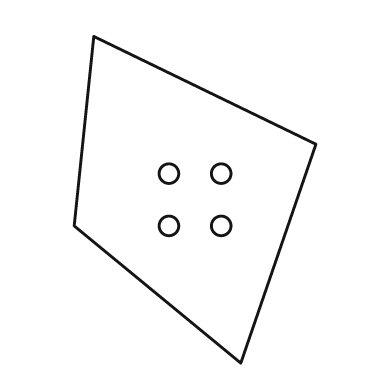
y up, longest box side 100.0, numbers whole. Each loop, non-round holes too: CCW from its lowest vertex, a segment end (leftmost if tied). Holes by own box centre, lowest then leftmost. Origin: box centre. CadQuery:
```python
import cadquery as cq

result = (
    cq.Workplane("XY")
    .moveTo(14.0, -50.0)
    .lineTo(37.0, 17.0)
    .lineTo(-31.0, 50.0)
    .lineTo(-37.0, -8.0)
    .close()
    .moveTo(-8.0, -8.0)
    .circle(3.0)
    .moveTo(8.0, -8.0)
    .circle(3.0)
    .moveTo(-8.0, 8.0)
    .circle(3.0)
    .moveTo(8.0, 8.0)
    .circle(3.0)
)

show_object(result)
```